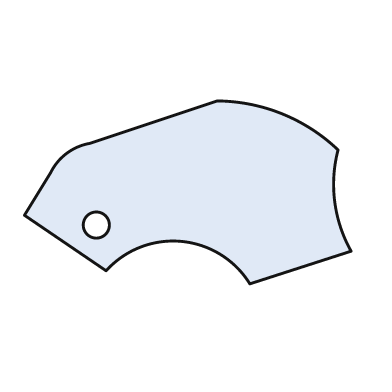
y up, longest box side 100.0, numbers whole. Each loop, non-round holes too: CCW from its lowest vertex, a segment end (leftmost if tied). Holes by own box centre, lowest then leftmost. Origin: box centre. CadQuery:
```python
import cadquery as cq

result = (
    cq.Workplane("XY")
    .moveTo(19.0, -28.0)
    .lineTo(50.0, -18.0)
    .threePointArc((45.0, -3.0), (46.0, 13.0))
    .threePointArc((29.0, 24.0), (9.0, 28.0))
    .lineTo(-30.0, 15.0)
    .threePointArc((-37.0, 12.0), (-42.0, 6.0))
    .lineTo(-50.0, -7.0)
    .lineTo(-25.0, -24.0)
    .threePointArc((-2.0, -15.0), (19.0, -28.0))
    .close()
    .moveTo(-28.0, -10.0)
    .circle(4.0)
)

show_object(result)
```